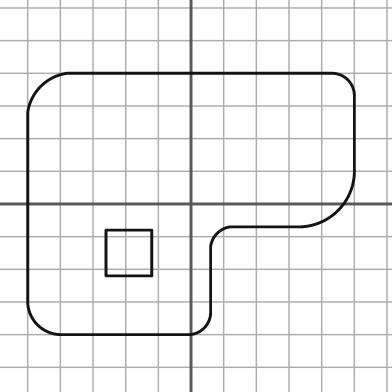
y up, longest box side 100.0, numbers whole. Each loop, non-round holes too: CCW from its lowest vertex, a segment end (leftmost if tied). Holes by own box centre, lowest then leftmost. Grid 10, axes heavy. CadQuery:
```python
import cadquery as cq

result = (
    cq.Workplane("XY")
    .moveTo(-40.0, -40.0)
    .lineTo(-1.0, -40.0)
    .threePointArc((4.0, -38.0), (6.0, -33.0))
    .lineTo(6.0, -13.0)
    .threePointArc((8.0, -9.0), (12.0, -7.0))
    .lineTo(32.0, -7.0)
    .threePointArc((45.0, -2.0), (50.0, 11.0))
    .lineTo(50.0, 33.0)
    .threePointArc((48.0, 38.0), (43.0, 40.0))
    .lineTo(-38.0, 40.0)
    .threePointArc((-46.0, 36.0), (-50.0, 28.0))
    .lineTo(-50.0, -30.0)
    .threePointArc((-47.0, -37.0), (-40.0, -40.0))
    .close()
    .moveTo(-26.0, -22.0)
    .lineTo(-12.0, -22.0)
    .lineTo(-12.0, -8.0)
    .lineTo(-26.0, -8.0)
    .close()
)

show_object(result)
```